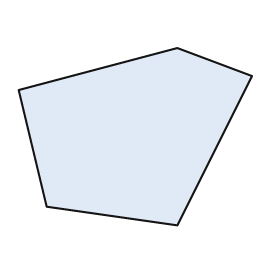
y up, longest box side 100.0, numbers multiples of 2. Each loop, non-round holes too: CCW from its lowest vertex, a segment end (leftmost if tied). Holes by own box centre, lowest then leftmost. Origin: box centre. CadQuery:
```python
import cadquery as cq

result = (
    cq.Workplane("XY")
    .moveTo(18.0, -38.0)
    .lineTo(50.0, 26.0)
    .lineTo(18.0, 38.0)
    .lineTo(-50.0, 20.0)
    .lineTo(-38.0, -30.0)
    .close()
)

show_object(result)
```